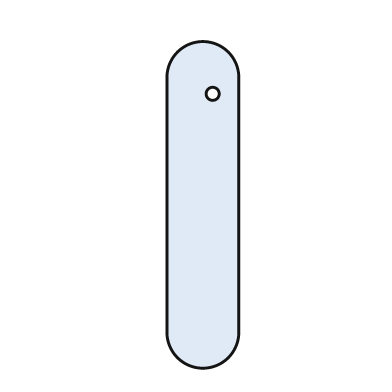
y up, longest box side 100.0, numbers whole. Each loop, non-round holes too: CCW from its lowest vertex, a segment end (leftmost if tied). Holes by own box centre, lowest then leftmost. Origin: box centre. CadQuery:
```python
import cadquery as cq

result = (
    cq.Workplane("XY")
    .moveTo(-11.0, -39.0)
    .threePointArc((0.0, -50.0), (11.0, -39.0))
    .lineTo(11.0, 39.0)
    .threePointArc((0.0, 50.0), (-11.0, 39.0))
    .close()
    .moveTo(3.0, 34.0)
    .circle(2.0)
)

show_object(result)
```